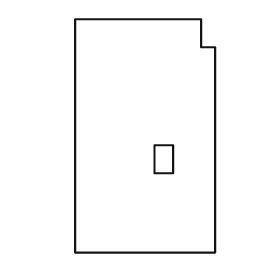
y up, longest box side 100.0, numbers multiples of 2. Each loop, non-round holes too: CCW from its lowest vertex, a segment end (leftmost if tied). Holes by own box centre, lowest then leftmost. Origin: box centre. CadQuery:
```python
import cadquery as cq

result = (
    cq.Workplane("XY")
    .moveTo(-30.0, -50.0)
    .lineTo(30.0, -50.0)
    .lineTo(30.0, 38.0)
    .lineTo(24.0, 38.0)
    .lineTo(24.0, 50.0)
    .lineTo(-30.0, 50.0)
    .close()
    .moveTo(4.0, -16.0)
    .lineTo(12.0, -16.0)
    .lineTo(12.0, -4.0)
    .lineTo(4.0, -4.0)
    .close()
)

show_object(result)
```